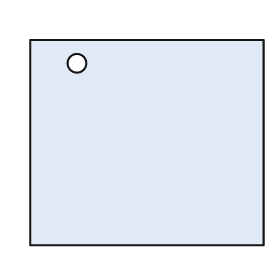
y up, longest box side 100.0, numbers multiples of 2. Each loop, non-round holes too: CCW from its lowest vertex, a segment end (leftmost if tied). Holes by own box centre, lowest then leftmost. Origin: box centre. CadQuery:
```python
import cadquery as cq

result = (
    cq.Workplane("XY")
    .moveTo(-50.0, -44.0)
    .lineTo(50.0, -44.0)
    .lineTo(50.0, 44.0)
    .lineTo(-50.0, 44.0)
    .close()
    .moveTo(-30.0, 34.0)
    .circle(4.0)
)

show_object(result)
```